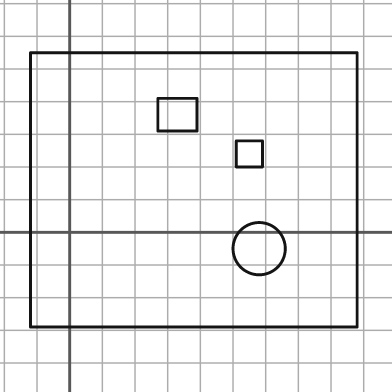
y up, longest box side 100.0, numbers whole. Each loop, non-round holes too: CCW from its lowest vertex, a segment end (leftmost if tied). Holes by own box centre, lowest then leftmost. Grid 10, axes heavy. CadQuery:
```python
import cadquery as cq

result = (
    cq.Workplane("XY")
    .moveTo(-12.0, -29.0)
    .lineTo(88.0, -29.0)
    .lineTo(88.0, 55.0)
    .lineTo(-12.0, 55.0)
    .close()
    .moveTo(58.0, -5.0)
    .circle(8.0)
    .moveTo(51.0, 20.0)
    .lineTo(59.0, 20.0)
    .lineTo(59.0, 28.0)
    .lineTo(51.0, 28.0)
    .close()
    .moveTo(27.0, 31.0)
    .lineTo(39.0, 31.0)
    .lineTo(39.0, 41.0)
    .lineTo(27.0, 41.0)
    .close()
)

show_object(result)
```